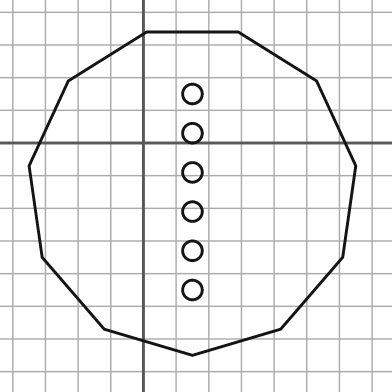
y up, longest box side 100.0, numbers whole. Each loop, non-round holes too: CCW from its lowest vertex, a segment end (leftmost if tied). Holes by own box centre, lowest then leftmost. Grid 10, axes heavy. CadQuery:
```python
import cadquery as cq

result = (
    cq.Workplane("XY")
    .moveTo(15.0, -65.0)
    .lineTo(42.0, -57.0)
    .lineTo(61.0, -35.0)
    .lineTo(65.0, -7.0)
    .lineTo(53.0, 19.0)
    .lineTo(29.0, 34.0)
    .lineTo(1.0, 34.0)
    .lineTo(-23.0, 19.0)
    .lineTo(-35.0, -7.0)
    .lineTo(-31.0, -35.0)
    .lineTo(-12.0, -57.0)
    .close()
    .moveTo(15.0, -45.0)
    .circle(3.0)
    .moveTo(15.0, -33.0)
    .circle(3.0)
    .moveTo(15.0, -21.0)
    .circle(3.0)
    .moveTo(15.0, -9.0)
    .circle(3.0)
    .moveTo(15.0, 3.0)
    .circle(3.0)
    .moveTo(15.0, 15.0)
    .circle(3.0)
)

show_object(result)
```